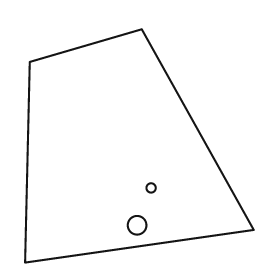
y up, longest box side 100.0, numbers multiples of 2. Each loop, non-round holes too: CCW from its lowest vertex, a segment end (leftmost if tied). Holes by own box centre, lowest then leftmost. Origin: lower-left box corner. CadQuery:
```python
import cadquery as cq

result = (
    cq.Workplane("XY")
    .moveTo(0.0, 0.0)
    .lineTo(98.0, 14.0)
    .lineTo(50.0, 100.0)
    .lineTo(2.0, 86.0)
    .close()
    .moveTo(48.0, 16.0)
    .circle(4.0)
    .moveTo(54.0, 32.0)
    .circle(2.0)
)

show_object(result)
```